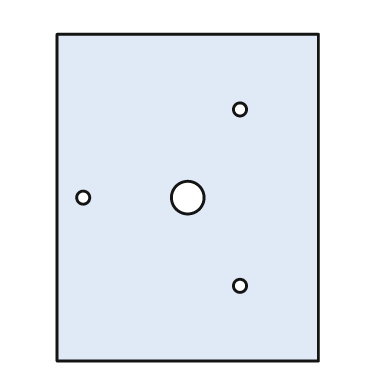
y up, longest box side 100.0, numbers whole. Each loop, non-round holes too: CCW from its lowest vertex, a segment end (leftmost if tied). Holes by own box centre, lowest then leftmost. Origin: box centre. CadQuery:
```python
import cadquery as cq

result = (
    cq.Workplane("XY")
    .moveTo(-40.0, -50.0)
    .lineTo(40.0, -50.0)
    .lineTo(40.0, 50.0)
    .lineTo(-40.0, 50.0)
    .close()
    .moveTo(16.0, -27.0)
    .circle(2.0)
    .moveTo(-32.0, 0.0)
    .circle(2.0)
    .moveTo(0.0, 0.0)
    .circle(5.0)
    .moveTo(16.0, 27.0)
    .circle(2.0)
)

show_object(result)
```